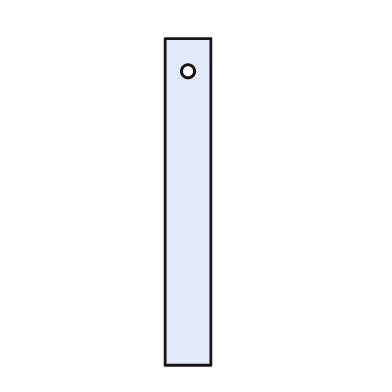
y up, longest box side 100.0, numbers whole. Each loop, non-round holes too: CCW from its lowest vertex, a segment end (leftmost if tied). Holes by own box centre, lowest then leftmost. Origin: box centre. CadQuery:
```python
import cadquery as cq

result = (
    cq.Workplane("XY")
    .moveTo(-7.0, -50.0)
    .lineTo(7.0, -50.0)
    .lineTo(7.0, 50.0)
    .lineTo(-7.0, 50.0)
    .close()
    .moveTo(0.0, 40.0)
    .circle(2.0)
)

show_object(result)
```